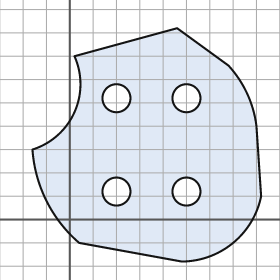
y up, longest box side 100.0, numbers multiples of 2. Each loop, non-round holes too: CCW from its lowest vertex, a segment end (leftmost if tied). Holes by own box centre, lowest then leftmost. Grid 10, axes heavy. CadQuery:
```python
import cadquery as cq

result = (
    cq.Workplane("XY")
    .moveTo(48.0, -18.0)
    .threePointArc((70.0, -10.0), (82.0, 10.0))
    .lineTo(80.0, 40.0)
    .threePointArc((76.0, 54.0), (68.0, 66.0))
    .lineTo(46.0, 82.0)
    .lineTo(2.0, 70.0)
    .threePointArc((2.0, 46.0), (-16.0, 30.0))
    .threePointArc((-10.0, 8.0), (4.0, -10.0))
    .close()
    .moveTo(20.0, 12.0)
    .circle(6.0)
    .moveTo(50.0, 12.0)
    .circle(6.0)
    .moveTo(20.0, 52.0)
    .circle(6.0)
    .moveTo(50.0, 52.0)
    .circle(6.0)
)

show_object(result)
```